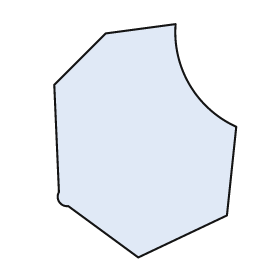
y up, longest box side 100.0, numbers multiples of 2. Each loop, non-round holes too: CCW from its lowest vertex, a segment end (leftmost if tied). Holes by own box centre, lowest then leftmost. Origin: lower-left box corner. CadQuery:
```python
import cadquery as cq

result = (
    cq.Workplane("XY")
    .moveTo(36.0, 0.0)
    .lineTo(74.0, 18.0)
    .lineTo(78.0, 56.0)
    .threePointArc((58.0, 74.0), (52.0, 100.0))
    .lineTo(22.0, 96.0)
    .lineTo(0.0, 74.0)
    .lineTo(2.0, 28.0)
    .threePointArc((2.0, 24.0), (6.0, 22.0))
    .close()
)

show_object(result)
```